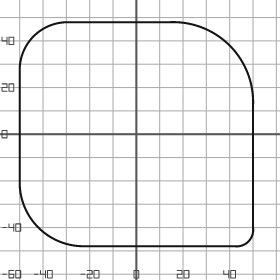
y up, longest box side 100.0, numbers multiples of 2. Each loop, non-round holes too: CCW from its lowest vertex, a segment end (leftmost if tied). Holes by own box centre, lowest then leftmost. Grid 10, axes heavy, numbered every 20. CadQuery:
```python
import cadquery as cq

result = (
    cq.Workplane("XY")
    .moveTo(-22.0, -48.0)
    .lineTo(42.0, -48.0)
    .threePointArc((48.0, -46.0), (50.0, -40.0))
    .lineTo(50.0, 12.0)
    .threePointArc((40.0, 38.0), (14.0, 48.0))
    .lineTo(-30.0, 48.0)
    .threePointArc((-44.0, 42.0), (-50.0, 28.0))
    .lineTo(-50.0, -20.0)
    .threePointArc((-42.0, -40.0), (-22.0, -48.0))
    .close()
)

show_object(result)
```